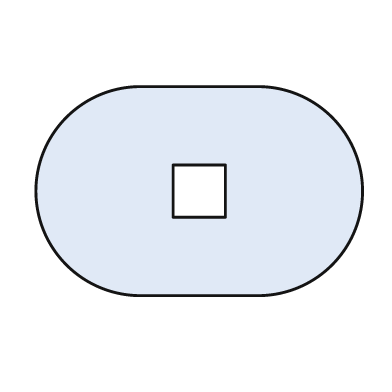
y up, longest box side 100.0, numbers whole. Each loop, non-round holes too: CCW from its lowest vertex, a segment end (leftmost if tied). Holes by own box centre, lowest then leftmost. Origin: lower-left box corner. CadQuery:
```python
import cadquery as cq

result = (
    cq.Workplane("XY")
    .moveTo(32.0, 0.0)
    .lineTo(68.0, 0.0)
    .threePointArc((100.0, 32.0), (68.0, 64.0))
    .lineTo(32.0, 64.0)
    .threePointArc((0.0, 32.0), (32.0, 0.0))
    .close()
    .moveTo(42.0, 24.0)
    .lineTo(58.0, 24.0)
    .lineTo(58.0, 40.0)
    .lineTo(42.0, 40.0)
    .close()
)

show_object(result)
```